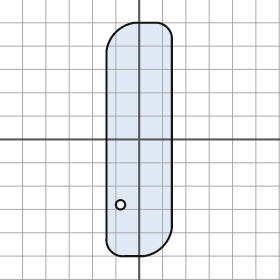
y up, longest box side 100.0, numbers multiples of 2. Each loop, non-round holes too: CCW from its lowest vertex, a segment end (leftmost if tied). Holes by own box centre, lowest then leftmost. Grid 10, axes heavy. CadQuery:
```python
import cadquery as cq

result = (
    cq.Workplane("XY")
    .moveTo(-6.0, -50.0)
    .lineTo(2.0, -50.0)
    .threePointArc((10.0, -46.0), (14.0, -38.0))
    .lineTo(14.0, 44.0)
    .threePointArc((12.0, 48.0), (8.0, 50.0))
    .lineTo(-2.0, 50.0)
    .threePointArc((-10.0, 46.0), (-14.0, 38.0))
    .lineTo(-14.0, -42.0)
    .threePointArc((-12.0, -48.0), (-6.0, -50.0))
    .close()
    .moveTo(-8.0, -28.0)
    .circle(2.0)
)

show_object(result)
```